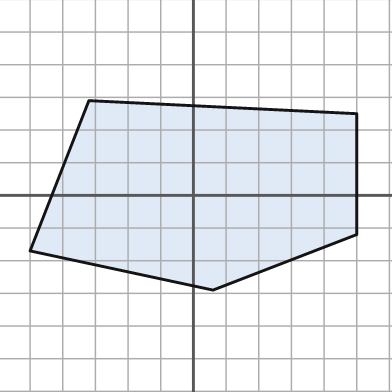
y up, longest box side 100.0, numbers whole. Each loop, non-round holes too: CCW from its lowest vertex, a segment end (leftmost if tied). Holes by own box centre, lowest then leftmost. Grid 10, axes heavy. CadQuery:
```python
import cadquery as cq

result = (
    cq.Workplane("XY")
    .moveTo(6.0, -29.0)
    .lineTo(50.0, -12.0)
    .lineTo(50.0, 25.0)
    .lineTo(-32.0, 29.0)
    .lineTo(-50.0, -17.0)
    .close()
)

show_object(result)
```